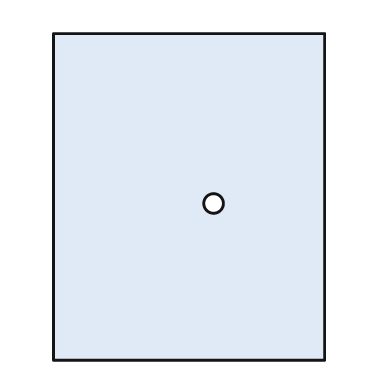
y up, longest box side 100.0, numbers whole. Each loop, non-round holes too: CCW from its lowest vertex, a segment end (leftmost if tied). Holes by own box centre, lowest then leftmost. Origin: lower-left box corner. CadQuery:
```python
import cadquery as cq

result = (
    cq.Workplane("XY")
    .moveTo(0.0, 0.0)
    .lineTo(83.0, 0.0)
    .lineTo(83.0, 100.0)
    .lineTo(0.0, 100.0)
    .close()
    .moveTo(49.0, 48.0)
    .circle(3.0)
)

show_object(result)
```